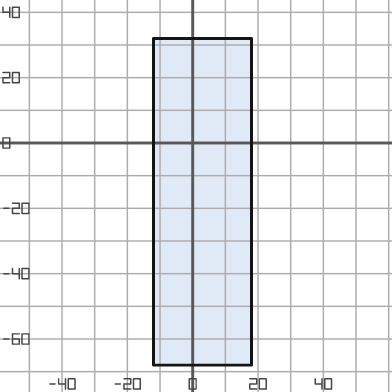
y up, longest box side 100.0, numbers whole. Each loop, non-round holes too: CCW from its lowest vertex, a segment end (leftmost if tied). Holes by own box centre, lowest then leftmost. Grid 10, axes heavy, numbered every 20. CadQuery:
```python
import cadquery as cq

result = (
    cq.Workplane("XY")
    .moveTo(-12.0, -68.0)
    .lineTo(18.0, -68.0)
    .lineTo(18.0, 32.0)
    .lineTo(-12.0, 32.0)
    .close()
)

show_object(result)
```